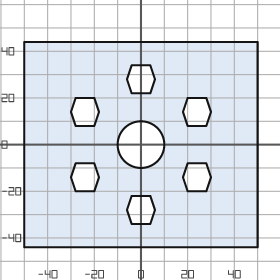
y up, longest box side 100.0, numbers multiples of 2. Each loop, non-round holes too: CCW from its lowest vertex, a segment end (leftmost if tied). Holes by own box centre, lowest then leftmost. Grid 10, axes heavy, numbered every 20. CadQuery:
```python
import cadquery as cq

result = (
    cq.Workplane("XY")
    .moveTo(-50.0, -44.0)
    .lineTo(50.0, -44.0)
    .lineTo(50.0, 44.0)
    .lineTo(-50.0, 44.0)
    .close()
    .moveTo(-4.0, -34.0)
    .lineTo(4.0, -34.0)
    .lineTo(6.0, -28.0)
    .lineTo(4.0, -22.0)
    .lineTo(-4.0, -22.0)
    .lineTo(-6.0, -28.0)
    .close()
    .moveTo(-28.0, -20.0)
    .lineTo(-20.0, -20.0)
    .lineTo(-18.0, -14.0)
    .lineTo(-20.0, -8.0)
    .lineTo(-28.0, -8.0)
    .lineTo(-30.0, -14.0)
    .close()
    .moveTo(20.0, -20.0)
    .lineTo(28.0, -20.0)
    .lineTo(30.0, -14.0)
    .lineTo(28.0, -8.0)
    .lineTo(20.0, -8.0)
    .lineTo(18.0, -14.0)
    .close()
    .moveTo(0.0, 0.0)
    .circle(10.0)
    .moveTo(-28.0, 8.0)
    .lineTo(-20.0, 8.0)
    .lineTo(-18.0, 14.0)
    .lineTo(-20.0, 20.0)
    .lineTo(-28.0, 20.0)
    .lineTo(-30.0, 14.0)
    .close()
    .moveTo(20.0, 8.0)
    .lineTo(28.0, 8.0)
    .lineTo(30.0, 14.0)
    .lineTo(28.0, 20.0)
    .lineTo(20.0, 20.0)
    .lineTo(18.0, 14.0)
    .close()
    .moveTo(-4.0, 22.0)
    .lineTo(4.0, 22.0)
    .lineTo(6.0, 28.0)
    .lineTo(4.0, 34.0)
    .lineTo(-4.0, 34.0)
    .lineTo(-6.0, 28.0)
    .close()
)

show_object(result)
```